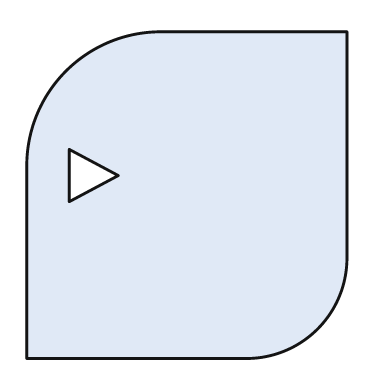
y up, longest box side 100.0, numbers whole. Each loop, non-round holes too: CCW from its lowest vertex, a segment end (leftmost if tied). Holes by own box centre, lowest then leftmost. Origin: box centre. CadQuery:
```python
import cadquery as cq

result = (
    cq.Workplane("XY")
    .moveTo(-49.0, -50.0)
    .lineTo(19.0, -50.0)
    .threePointArc((40.0, -41.0), (49.0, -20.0))
    .lineTo(49.0, 50.0)
    .lineTo(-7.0, 50.0)
    .threePointArc((-37.0, 38.0), (-49.0, 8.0))
    .close()
    .moveTo(-36.0, -2.0)
    .lineTo(-21.0, 6.0)
    .lineTo(-36.0, 14.0)
    .close()
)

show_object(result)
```